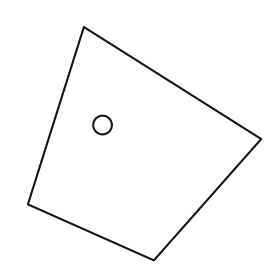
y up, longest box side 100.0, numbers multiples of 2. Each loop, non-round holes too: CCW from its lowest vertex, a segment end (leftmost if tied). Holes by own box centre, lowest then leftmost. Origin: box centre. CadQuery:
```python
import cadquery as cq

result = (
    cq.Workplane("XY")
    .moveTo(4.0, -50.0)
    .lineTo(50.0, 2.0)
    .lineTo(-26.0, 50.0)
    .lineTo(-50.0, -26.0)
    .close()
    .moveTo(-18.0, 8.0)
    .circle(4.0)
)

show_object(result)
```